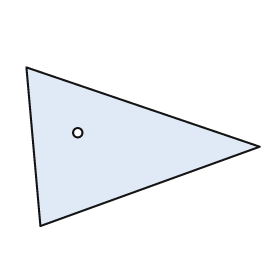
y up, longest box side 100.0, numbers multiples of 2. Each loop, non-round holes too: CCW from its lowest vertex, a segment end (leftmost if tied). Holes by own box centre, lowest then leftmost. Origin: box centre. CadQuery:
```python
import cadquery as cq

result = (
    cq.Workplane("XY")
    .moveTo(-44.0, -34.0)
    .lineTo(50.0, 0.0)
    .lineTo(-50.0, 34.0)
    .close()
    .moveTo(-28.0, 6.0)
    .circle(2.0)
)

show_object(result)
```